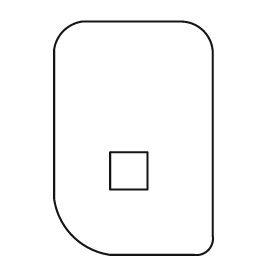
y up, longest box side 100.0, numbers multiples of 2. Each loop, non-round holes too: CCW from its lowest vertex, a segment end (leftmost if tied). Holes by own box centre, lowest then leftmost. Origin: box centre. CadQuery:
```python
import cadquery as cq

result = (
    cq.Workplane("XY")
    .moveTo(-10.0, -50.0)
    .lineTo(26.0, -50.0)
    .threePointArc((32.0, -48.0), (34.0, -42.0))
    .lineTo(34.0, 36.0)
    .threePointArc((30.0, 46.0), (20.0, 50.0))
    .lineTo(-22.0, 50.0)
    .threePointArc((-30.0, 46.0), (-34.0, 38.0))
    .lineTo(-34.0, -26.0)
    .threePointArc((-26.0, -42.0), (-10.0, -50.0))
    .close()
    .moveTo(-10.0, -22.0)
    .lineTo(6.0, -22.0)
    .lineTo(6.0, -6.0)
    .lineTo(-10.0, -6.0)
    .close()
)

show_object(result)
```